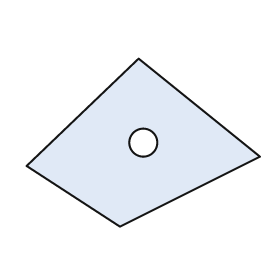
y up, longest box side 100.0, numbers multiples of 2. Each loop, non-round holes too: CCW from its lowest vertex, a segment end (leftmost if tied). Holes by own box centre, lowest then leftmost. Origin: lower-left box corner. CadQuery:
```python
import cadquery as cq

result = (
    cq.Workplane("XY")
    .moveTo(40.0, 0.0)
    .lineTo(100.0, 30.0)
    .lineTo(48.0, 72.0)
    .lineTo(0.0, 26.0)
    .close()
    .moveTo(50.0, 36.0)
    .circle(6.0)
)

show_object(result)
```